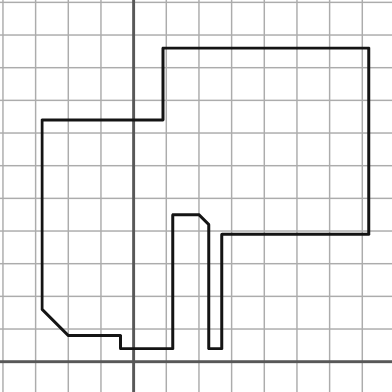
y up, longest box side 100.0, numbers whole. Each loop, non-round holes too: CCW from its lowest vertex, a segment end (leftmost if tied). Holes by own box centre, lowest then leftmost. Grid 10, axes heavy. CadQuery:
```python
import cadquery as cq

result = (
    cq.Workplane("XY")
    .moveTo(-4.0, 4.0)
    .lineTo(12.0, 4.0)
    .lineTo(12.0, 45.0)
    .lineTo(20.0, 45.0)
    .lineTo(23.0, 42.0)
    .lineTo(23.0, 4.0)
    .lineTo(27.0, 4.0)
    .lineTo(27.0, 39.0)
    .lineTo(72.0, 39.0)
    .lineTo(72.0, 96.0)
    .lineTo(9.0, 96.0)
    .lineTo(9.0, 74.0)
    .lineTo(-28.0, 74.0)
    .lineTo(-28.0, 16.0)
    .lineTo(-20.0, 8.0)
    .lineTo(-4.0, 8.0)
    .close()
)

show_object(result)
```